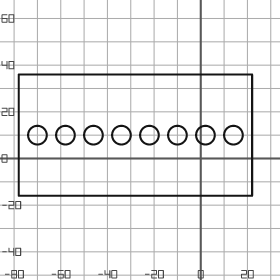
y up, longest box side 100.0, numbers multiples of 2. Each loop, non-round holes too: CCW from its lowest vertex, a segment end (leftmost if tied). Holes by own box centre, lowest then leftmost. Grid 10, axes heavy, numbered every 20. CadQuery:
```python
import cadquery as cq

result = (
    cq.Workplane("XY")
    .moveTo(-78.0, -16.0)
    .lineTo(22.0, -16.0)
    .lineTo(22.0, 36.0)
    .lineTo(-78.0, 36.0)
    .close()
    .moveTo(-70.0, 10.0)
    .circle(4.0)
    .moveTo(-58.0, 10.0)
    .circle(4.0)
    .moveTo(-46.0, 10.0)
    .circle(4.0)
    .moveTo(-34.0, 10.0)
    .circle(4.0)
    .moveTo(-22.0, 10.0)
    .circle(4.0)
    .moveTo(-10.0, 10.0)
    .circle(4.0)
    .moveTo(2.0, 10.0)
    .circle(4.0)
    .moveTo(14.0, 10.0)
    .circle(4.0)
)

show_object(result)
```